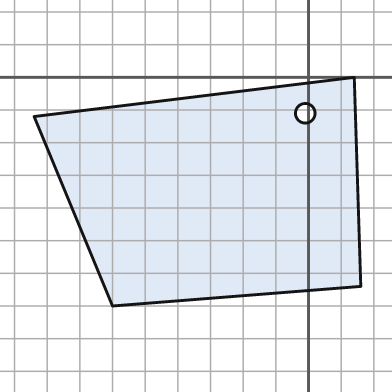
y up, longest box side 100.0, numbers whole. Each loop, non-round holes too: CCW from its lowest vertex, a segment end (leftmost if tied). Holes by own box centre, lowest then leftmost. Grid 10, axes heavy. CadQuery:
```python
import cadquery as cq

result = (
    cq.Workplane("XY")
    .moveTo(-60.0, -70.0)
    .lineTo(16.0, -64.0)
    .lineTo(14.0, 0.0)
    .lineTo(-84.0, -12.0)
    .close()
    .moveTo(-1.0, -11.0)
    .circle(3.0)
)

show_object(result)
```